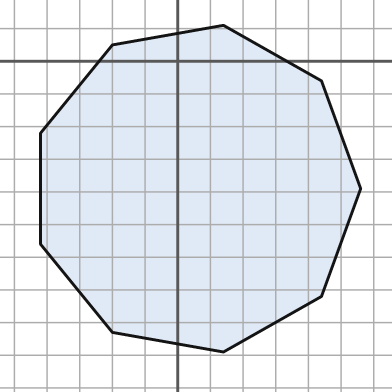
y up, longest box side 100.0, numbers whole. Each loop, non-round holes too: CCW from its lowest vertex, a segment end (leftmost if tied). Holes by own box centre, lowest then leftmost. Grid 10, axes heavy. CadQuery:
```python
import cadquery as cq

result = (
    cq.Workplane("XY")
    .moveTo(14.0, -89.0)
    .lineTo(44.0, -72.0)
    .lineTo(56.0, -39.0)
    .lineTo(44.0, -6.0)
    .lineTo(14.0, 11.0)
    .lineTo(-20.0, 5.0)
    .lineTo(-42.0, -22.0)
    .lineTo(-42.0, -56.0)
    .lineTo(-20.0, -83.0)
    .close()
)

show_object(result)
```